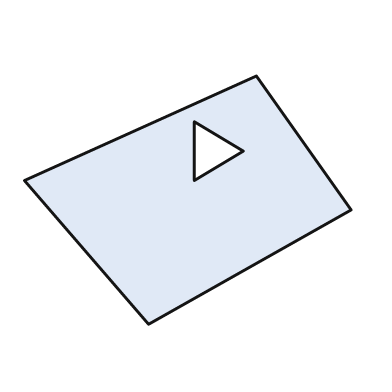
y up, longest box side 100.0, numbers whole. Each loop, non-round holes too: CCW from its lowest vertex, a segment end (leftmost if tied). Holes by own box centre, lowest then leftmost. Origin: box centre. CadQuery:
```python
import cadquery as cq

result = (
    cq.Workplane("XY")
    .moveTo(-12.0, -38.0)
    .lineTo(50.0, -3.0)
    .lineTo(21.0, 38.0)
    .lineTo(-50.0, 6.0)
    .close()
    .moveTo(2.0, 6.0)
    .lineTo(17.0, 15.0)
    .lineTo(2.0, 24.0)
    .close()
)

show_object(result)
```